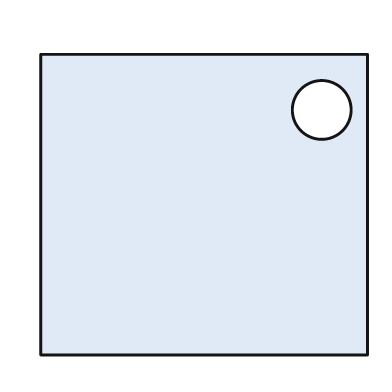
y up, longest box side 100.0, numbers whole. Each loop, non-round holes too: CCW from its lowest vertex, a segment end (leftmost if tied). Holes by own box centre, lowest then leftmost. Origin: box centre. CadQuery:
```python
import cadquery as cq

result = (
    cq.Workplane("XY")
    .moveTo(-50.0, -46.0)
    .lineTo(50.0, -46.0)
    .lineTo(50.0, 46.0)
    .lineTo(-50.0, 46.0)
    .close()
    .moveTo(36.0, 29.0)
    .circle(9.0)
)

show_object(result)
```